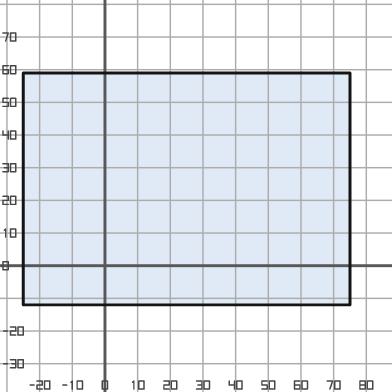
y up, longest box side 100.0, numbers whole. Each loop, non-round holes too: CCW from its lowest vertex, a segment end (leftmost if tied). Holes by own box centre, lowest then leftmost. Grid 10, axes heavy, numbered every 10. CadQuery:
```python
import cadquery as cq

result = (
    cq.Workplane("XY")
    .moveTo(-25.0, -12.0)
    .lineTo(75.0, -12.0)
    .lineTo(75.0, 59.0)
    .lineTo(-25.0, 59.0)
    .close()
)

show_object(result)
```